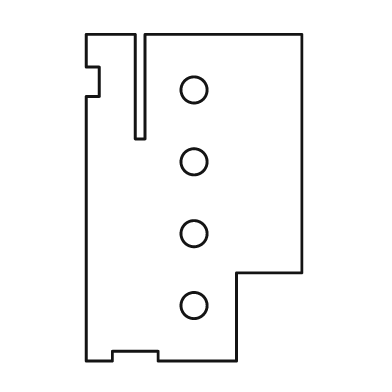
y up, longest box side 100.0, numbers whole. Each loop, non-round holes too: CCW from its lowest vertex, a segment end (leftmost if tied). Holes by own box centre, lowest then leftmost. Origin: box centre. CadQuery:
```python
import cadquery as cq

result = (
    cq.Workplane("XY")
    .moveTo(-33.0, -50.0)
    .lineTo(-25.0, -50.0)
    .lineTo(-25.0, -47.0)
    .lineTo(-11.0, -47.0)
    .lineTo(-11.0, -50.0)
    .lineTo(13.0, -50.0)
    .lineTo(13.0, -23.0)
    .lineTo(33.0, -23.0)
    .lineTo(33.0, 50.0)
    .lineTo(-15.0, 50.0)
    .lineTo(-15.0, 18.0)
    .lineTo(-18.0, 18.0)
    .lineTo(-18.0, 50.0)
    .lineTo(-33.0, 50.0)
    .lineTo(-33.0, 40.0)
    .lineTo(-29.0, 40.0)
    .lineTo(-29.0, 31.0)
    .lineTo(-33.0, 31.0)
    .close()
    .moveTo(0.0, -33.0)
    .circle(4.0)
    .moveTo(0.0, -11.0)
    .circle(4.0)
    .moveTo(0.0, 11.0)
    .circle(4.0)
    .moveTo(0.0, 33.0)
    .circle(4.0)
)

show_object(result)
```